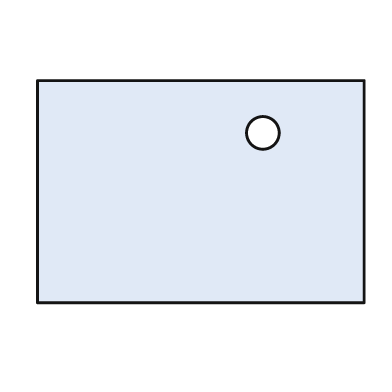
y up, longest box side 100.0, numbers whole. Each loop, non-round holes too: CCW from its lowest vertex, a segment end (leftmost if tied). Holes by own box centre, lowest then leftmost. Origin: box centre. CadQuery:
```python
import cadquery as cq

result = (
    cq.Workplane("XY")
    .moveTo(-50.0, -34.0)
    .lineTo(50.0, -34.0)
    .lineTo(50.0, 34.0)
    .lineTo(-50.0, 34.0)
    .close()
    .moveTo(19.0, 18.0)
    .circle(5.0)
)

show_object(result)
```